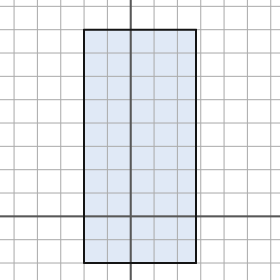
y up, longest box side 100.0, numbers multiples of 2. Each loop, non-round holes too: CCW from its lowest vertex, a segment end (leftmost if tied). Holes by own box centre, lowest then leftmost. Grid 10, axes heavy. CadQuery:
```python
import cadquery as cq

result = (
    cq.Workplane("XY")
    .moveTo(-20.0, -20.0)
    .lineTo(28.0, -20.0)
    .lineTo(28.0, 80.0)
    .lineTo(-20.0, 80.0)
    .close()
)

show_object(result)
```